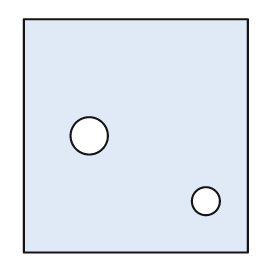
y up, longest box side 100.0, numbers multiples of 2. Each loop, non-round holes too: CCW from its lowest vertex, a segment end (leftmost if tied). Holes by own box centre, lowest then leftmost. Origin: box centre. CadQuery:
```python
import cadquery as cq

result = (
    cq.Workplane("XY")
    .moveTo(-48.0, -50.0)
    .lineTo(48.0, -50.0)
    .lineTo(48.0, 50.0)
    .lineTo(-48.0, 50.0)
    .close()
    .moveTo(30.0, -28.0)
    .circle(6.0)
    .moveTo(-20.0, 0.0)
    .circle(8.0)
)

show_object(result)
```